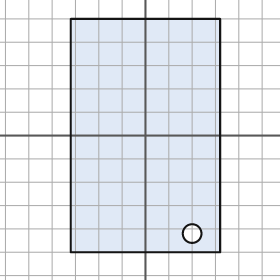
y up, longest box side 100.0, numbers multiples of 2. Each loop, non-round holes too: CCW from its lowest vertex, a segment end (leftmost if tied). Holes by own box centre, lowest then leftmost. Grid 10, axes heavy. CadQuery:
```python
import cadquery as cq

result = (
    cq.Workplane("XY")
    .moveTo(-32.0, -50.0)
    .lineTo(32.0, -50.0)
    .lineTo(32.0, 50.0)
    .lineTo(-32.0, 50.0)
    .close()
    .moveTo(20.0, -42.0)
    .circle(4.0)
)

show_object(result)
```